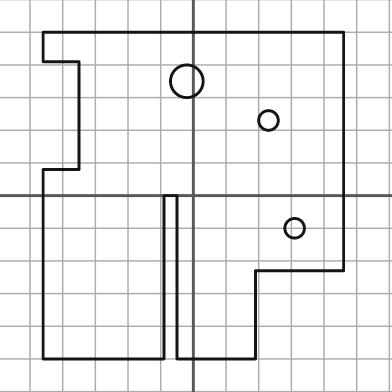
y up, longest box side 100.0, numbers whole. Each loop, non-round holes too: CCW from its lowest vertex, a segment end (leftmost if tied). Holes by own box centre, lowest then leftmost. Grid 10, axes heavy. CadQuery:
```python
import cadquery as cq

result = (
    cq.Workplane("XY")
    .moveTo(-46.0, -50.0)
    .lineTo(-9.0, -50.0)
    .lineTo(-9.0, 0.0)
    .lineTo(-5.0, 0.0)
    .lineTo(-5.0, -50.0)
    .lineTo(19.0, -50.0)
    .lineTo(19.0, -23.0)
    .lineTo(46.0, -23.0)
    .lineTo(46.0, 50.0)
    .lineTo(-46.0, 50.0)
    .lineTo(-46.0, 41.0)
    .lineTo(-35.0, 41.0)
    .lineTo(-35.0, 8.0)
    .lineTo(-46.0, 8.0)
    .close()
    .moveTo(31.0, -10.0)
    .circle(3.0)
    .moveTo(23.0, 23.0)
    .circle(3.0)
    .moveTo(-2.0, 35.0)
    .circle(5.0)
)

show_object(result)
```